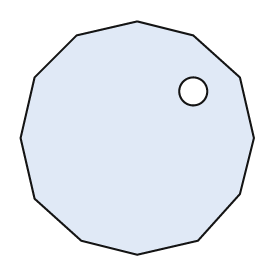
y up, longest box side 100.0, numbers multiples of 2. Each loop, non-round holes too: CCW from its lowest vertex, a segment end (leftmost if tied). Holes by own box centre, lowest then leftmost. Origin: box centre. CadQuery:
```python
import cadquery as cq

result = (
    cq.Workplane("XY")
    .moveTo(0.0, -50.0)
    .lineTo(26.0, -44.0)
    .lineTo(44.0, -24.0)
    .lineTo(50.0, 0.0)
    .lineTo(44.0, 26.0)
    .lineTo(24.0, 44.0)
    .lineTo(0.0, 50.0)
    .lineTo(-26.0, 44.0)
    .lineTo(-44.0, 26.0)
    .lineTo(-50.0, 0.0)
    .lineTo(-44.0, -26.0)
    .lineTo(-24.0, -44.0)
    .close()
    .moveTo(24.0, 20.0)
    .circle(6.0)
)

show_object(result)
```